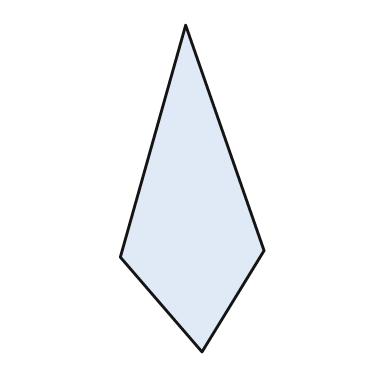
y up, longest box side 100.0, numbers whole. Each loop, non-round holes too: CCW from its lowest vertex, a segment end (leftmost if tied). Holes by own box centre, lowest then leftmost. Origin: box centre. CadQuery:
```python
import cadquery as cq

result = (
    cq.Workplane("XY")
    .moveTo(3.0, -50.0)
    .lineTo(22.0, -19.0)
    .lineTo(-2.0, 50.0)
    .lineTo(-22.0, -21.0)
    .close()
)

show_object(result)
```